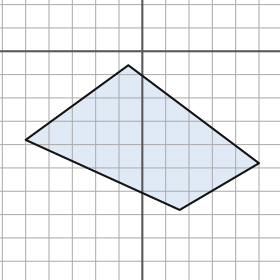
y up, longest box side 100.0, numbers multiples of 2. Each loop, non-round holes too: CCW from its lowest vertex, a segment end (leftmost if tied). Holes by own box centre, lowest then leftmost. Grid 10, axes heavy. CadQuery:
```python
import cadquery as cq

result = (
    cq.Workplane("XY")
    .moveTo(16.0, -68.0)
    .lineTo(50.0, -48.0)
    .lineTo(-6.0, -6.0)
    .lineTo(-50.0, -38.0)
    .close()
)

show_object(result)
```